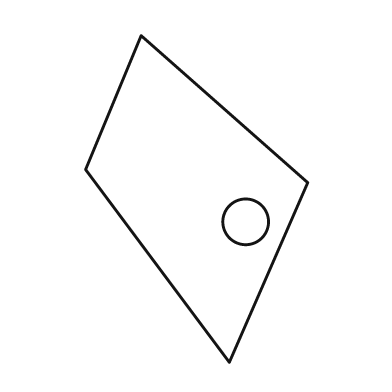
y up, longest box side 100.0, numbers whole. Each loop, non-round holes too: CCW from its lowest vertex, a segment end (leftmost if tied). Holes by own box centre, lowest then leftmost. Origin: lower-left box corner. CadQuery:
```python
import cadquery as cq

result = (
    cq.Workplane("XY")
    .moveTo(44.0, 0.0)
    .lineTo(68.0, 55.0)
    .lineTo(17.0, 100.0)
    .lineTo(0.0, 59.0)
    .close()
    .moveTo(49.0, 43.0)
    .circle(7.0)
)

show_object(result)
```